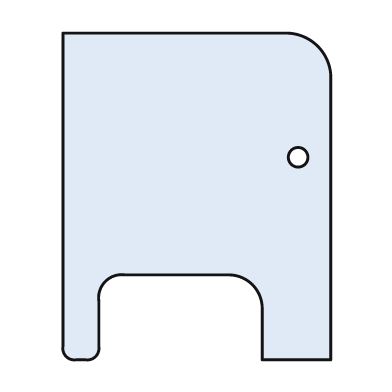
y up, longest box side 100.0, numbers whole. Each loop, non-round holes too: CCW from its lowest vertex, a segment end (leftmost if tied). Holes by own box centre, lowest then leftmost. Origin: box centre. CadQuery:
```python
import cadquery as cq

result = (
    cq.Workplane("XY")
    .moveTo(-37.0, -50.0)
    .lineTo(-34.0, -50.0)
    .threePointArc((-31.0, -49.0), (-30.0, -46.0))
    .lineTo(-30.0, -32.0)
    .threePointArc((-28.0, -26.0), (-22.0, -24.0))
    .lineTo(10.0, -24.0)
    .threePointArc((17.0, -27.0), (20.0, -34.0))
    .lineTo(20.0, -50.0)
    .lineTo(41.0, -50.0)
    .lineTo(41.0, 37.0)
    .threePointArc((37.0, 46.0), (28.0, 50.0))
    .lineTo(-41.0, 50.0)
    .lineTo(-41.0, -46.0)
    .threePointArc((-40.0, -49.0), (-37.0, -50.0))
    .close()
    .moveTo(31.0, 12.0)
    .circle(3.0)
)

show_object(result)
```